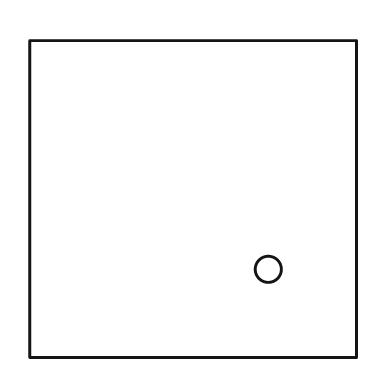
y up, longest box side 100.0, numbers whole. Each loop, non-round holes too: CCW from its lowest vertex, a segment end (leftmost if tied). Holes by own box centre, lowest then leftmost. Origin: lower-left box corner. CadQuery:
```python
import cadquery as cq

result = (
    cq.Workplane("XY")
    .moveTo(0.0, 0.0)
    .lineTo(100.0, 0.0)
    .lineTo(100.0, 97.0)
    .lineTo(0.0, 97.0)
    .close()
    .moveTo(73.0, 27.0)
    .circle(4.0)
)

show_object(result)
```